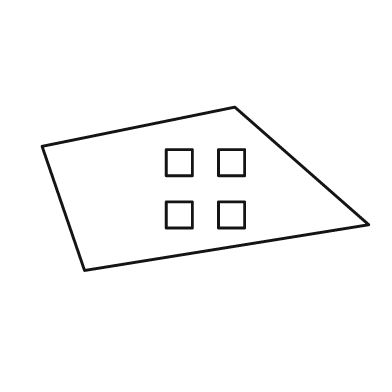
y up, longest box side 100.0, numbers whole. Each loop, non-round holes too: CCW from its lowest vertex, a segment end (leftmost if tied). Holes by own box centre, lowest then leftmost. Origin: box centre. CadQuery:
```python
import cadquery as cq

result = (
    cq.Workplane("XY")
    .moveTo(-37.0, -25.0)
    .lineTo(50.0, -11.0)
    .lineTo(9.0, 25.0)
    .lineTo(-50.0, 13.0)
    .close()
    .moveTo(-12.0, -12.0)
    .lineTo(-4.0, -12.0)
    .lineTo(-4.0, -4.0)
    .lineTo(-12.0, -4.0)
    .close()
    .moveTo(4.0, -12.0)
    .lineTo(12.0, -12.0)
    .lineTo(12.0, -4.0)
    .lineTo(4.0, -4.0)
    .close()
    .moveTo(-12.0, 4.0)
    .lineTo(-4.0, 4.0)
    .lineTo(-4.0, 12.0)
    .lineTo(-12.0, 12.0)
    .close()
    .moveTo(4.0, 4.0)
    .lineTo(12.0, 4.0)
    .lineTo(12.0, 12.0)
    .lineTo(4.0, 12.0)
    .close()
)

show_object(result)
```